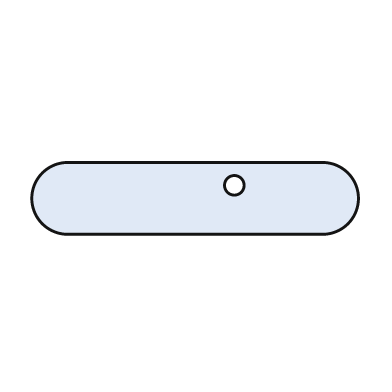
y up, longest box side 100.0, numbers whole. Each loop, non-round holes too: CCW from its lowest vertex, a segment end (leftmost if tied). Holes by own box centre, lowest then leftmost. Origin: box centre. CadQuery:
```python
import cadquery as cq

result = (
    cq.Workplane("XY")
    .moveTo(-39.0, -11.0)
    .lineTo(39.0, -11.0)
    .threePointArc((50.0, 0.0), (39.0, 11.0))
    .lineTo(-39.0, 11.0)
    .threePointArc((-50.0, 0.0), (-39.0, -11.0))
    .close()
    .moveTo(12.0, 4.0)
    .circle(3.0)
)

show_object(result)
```